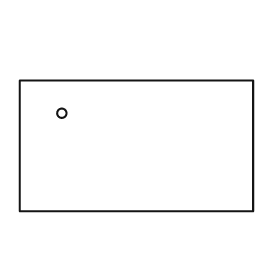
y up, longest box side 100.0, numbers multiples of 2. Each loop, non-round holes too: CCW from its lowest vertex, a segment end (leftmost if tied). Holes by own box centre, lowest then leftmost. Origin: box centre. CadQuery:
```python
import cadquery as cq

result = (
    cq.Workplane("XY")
    .moveTo(-50.0, -28.0)
    .lineTo(50.0, -28.0)
    .lineTo(50.0, 28.0)
    .lineTo(-50.0, 28.0)
    .close()
    .moveTo(-32.0, 14.0)
    .circle(2.0)
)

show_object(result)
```